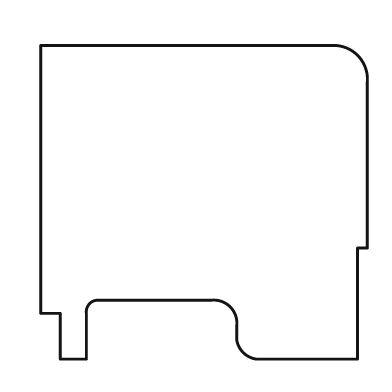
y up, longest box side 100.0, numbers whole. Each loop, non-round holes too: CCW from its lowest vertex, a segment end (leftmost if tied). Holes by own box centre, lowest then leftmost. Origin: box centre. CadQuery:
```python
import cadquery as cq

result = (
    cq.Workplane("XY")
    .moveTo(-44.0, -48.0)
    .lineTo(-36.0, -48.0)
    .lineTo(-36.0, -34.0)
    .threePointArc((-35.0, -31.0), (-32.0, -30.0))
    .lineTo(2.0, -30.0)
    .threePointArc((8.0, -32.0), (10.0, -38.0))
    .lineTo(10.0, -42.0)
    .threePointArc((12.0, -46.0), (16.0, -48.0))
    .lineTo(47.0, -48.0)
    .lineTo(47.0, -14.0)
    .lineTo(50.0, -14.0)
    .lineTo(50.0, 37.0)
    .threePointArc((47.0, 45.0), (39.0, 48.0))
    .lineTo(-50.0, 48.0)
    .lineTo(-50.0, -34.0)
    .lineTo(-44.0, -34.0)
    .close()
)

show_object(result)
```